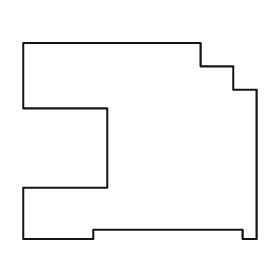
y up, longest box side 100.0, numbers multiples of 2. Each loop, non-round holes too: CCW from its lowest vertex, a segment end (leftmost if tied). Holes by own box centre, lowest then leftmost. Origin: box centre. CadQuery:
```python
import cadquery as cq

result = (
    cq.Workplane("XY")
    .moveTo(-50.0, -42.0)
    .lineTo(-20.0, -42.0)
    .lineTo(-20.0, -38.0)
    .lineTo(44.0, -38.0)
    .lineTo(44.0, -42.0)
    .lineTo(50.0, -42.0)
    .lineTo(50.0, 22.0)
    .lineTo(40.0, 22.0)
    .lineTo(40.0, 32.0)
    .lineTo(26.0, 32.0)
    .lineTo(26.0, 42.0)
    .lineTo(-50.0, 42.0)
    .lineTo(-50.0, 14.0)
    .lineTo(-14.0, 14.0)
    .lineTo(-14.0, -20.0)
    .lineTo(-50.0, -20.0)
    .close()
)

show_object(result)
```